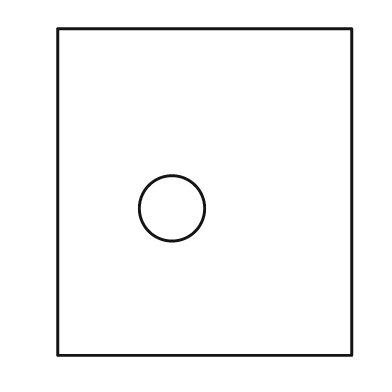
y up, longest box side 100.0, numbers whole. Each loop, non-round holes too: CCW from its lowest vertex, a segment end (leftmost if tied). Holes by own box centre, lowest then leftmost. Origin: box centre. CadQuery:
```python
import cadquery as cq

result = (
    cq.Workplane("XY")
    .moveTo(-45.0, -50.0)
    .lineTo(45.0, -50.0)
    .lineTo(45.0, 50.0)
    .lineTo(-45.0, 50.0)
    .close()
    .moveTo(-10.0, -5.0)
    .circle(10.0)
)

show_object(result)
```